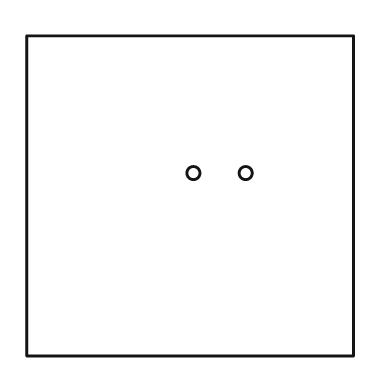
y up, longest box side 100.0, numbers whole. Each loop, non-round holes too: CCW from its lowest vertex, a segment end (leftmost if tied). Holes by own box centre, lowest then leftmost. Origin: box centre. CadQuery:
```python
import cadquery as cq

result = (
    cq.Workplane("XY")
    .moveTo(-50.0, -49.0)
    .lineTo(50.0, -49.0)
    .lineTo(50.0, 49.0)
    .lineTo(-50.0, 49.0)
    .close()
    .moveTo(1.0, 7.0)
    .circle(2.0)
    .moveTo(17.0, 7.0)
    .circle(2.0)
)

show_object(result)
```